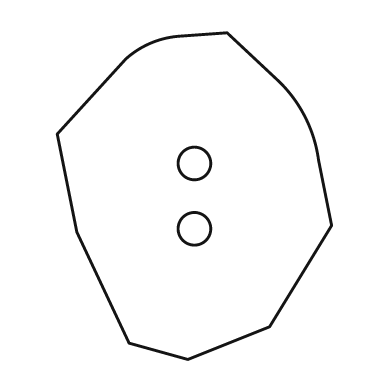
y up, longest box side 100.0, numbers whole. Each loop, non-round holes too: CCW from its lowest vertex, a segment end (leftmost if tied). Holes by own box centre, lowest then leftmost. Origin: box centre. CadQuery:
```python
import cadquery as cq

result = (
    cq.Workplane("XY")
    .moveTo(-2.0, -50.0)
    .lineTo(23.0, -40.0)
    .lineTo(42.0, -9.0)
    .lineTo(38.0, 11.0)
    .threePointArc((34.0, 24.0), (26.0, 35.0))
    .lineTo(10.0, 50.0)
    .lineTo(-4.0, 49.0)
    .threePointArc((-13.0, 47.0), (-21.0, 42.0))
    .lineTo(-42.0, 19.0)
    .lineTo(-36.0, -11.0)
    .lineTo(-20.0, -45.0)
    .close()
    .moveTo(0.0, -10.0)
    .circle(5.0)
    .moveTo(0.0, 10.0)
    .circle(5.0)
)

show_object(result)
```